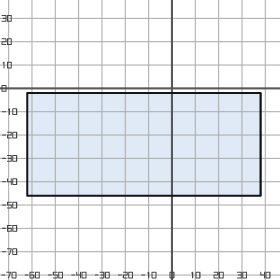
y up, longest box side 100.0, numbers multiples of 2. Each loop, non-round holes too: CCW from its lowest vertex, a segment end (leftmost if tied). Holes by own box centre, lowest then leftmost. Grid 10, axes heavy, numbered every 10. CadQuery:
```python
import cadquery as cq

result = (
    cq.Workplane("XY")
    .moveTo(-62.0, -46.0)
    .lineTo(38.0, -46.0)
    .lineTo(38.0, -2.0)
    .lineTo(-62.0, -2.0)
    .close()
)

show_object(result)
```